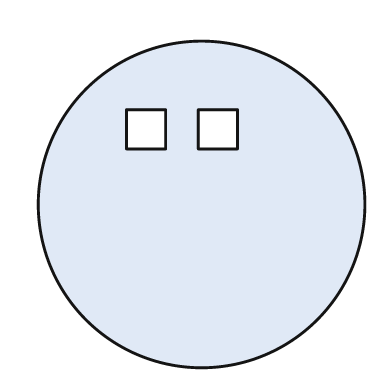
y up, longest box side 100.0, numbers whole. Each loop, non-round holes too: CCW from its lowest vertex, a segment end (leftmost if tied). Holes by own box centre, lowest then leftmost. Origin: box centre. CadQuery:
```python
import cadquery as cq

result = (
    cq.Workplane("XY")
    .moveTo(0.0, 0.0)
    .circle(50.0)
    .moveTo(-23.0, 17.0)
    .lineTo(-11.0, 17.0)
    .lineTo(-11.0, 29.0)
    .lineTo(-23.0, 29.0)
    .close()
    .moveTo(-1.0, 17.0)
    .lineTo(11.0, 17.0)
    .lineTo(11.0, 29.0)
    .lineTo(-1.0, 29.0)
    .close()
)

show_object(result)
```